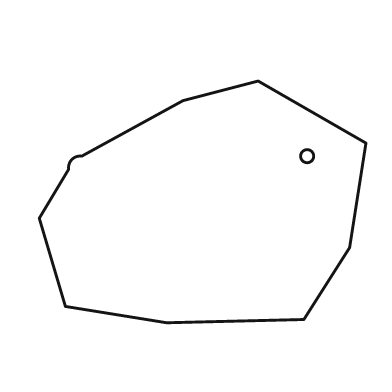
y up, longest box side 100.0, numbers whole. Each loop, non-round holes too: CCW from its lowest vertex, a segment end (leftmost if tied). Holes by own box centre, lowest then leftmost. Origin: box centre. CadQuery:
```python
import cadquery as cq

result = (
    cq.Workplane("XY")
    .moveTo(-11.0, -37.0)
    .lineTo(31.0, -36.0)
    .lineTo(45.0, -14.0)
    .lineTo(50.0, 18.0)
    .lineTo(17.0, 37.0)
    .lineTo(-6.0, 31.0)
    .lineTo(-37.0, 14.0)
    .threePointArc((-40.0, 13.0), (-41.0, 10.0))
    .lineTo(-50.0, -5.0)
    .lineTo(-42.0, -32.0)
    .close()
    .moveTo(32.0, 14.0)
    .circle(2.0)
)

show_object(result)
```